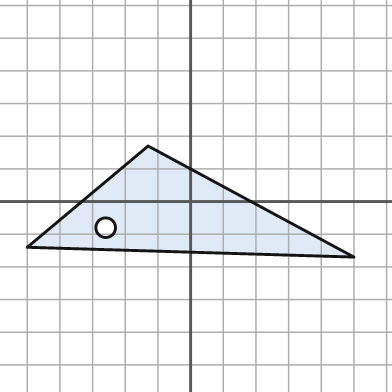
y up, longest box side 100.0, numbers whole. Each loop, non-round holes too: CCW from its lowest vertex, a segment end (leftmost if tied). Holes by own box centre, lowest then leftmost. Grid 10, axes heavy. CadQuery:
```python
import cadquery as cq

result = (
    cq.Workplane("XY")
    .moveTo(50.0, -17.0)
    .lineTo(-13.0, 17.0)
    .lineTo(-50.0, -14.0)
    .close()
    .moveTo(-26.0, -8.0)
    .circle(3.0)
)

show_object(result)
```